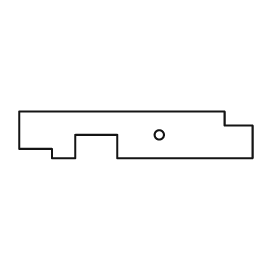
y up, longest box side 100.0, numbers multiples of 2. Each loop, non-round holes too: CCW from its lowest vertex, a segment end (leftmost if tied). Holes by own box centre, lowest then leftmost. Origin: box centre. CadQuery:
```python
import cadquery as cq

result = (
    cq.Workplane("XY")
    .moveTo(-36.0, -10.0)
    .lineTo(-26.0, -10.0)
    .lineTo(-26.0, 0.0)
    .lineTo(-8.0, 0.0)
    .lineTo(-8.0, -10.0)
    .lineTo(50.0, -10.0)
    .lineTo(50.0, 4.0)
    .lineTo(38.0, 4.0)
    .lineTo(38.0, 10.0)
    .lineTo(-50.0, 10.0)
    .lineTo(-50.0, -6.0)
    .lineTo(-36.0, -6.0)
    .close()
    .moveTo(10.0, 0.0)
    .circle(2.0)
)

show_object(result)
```